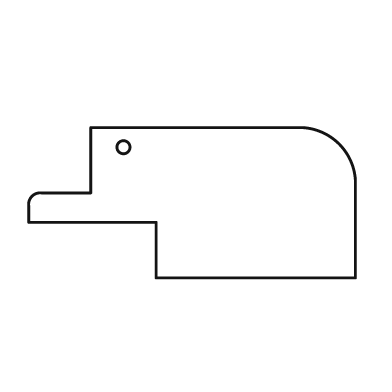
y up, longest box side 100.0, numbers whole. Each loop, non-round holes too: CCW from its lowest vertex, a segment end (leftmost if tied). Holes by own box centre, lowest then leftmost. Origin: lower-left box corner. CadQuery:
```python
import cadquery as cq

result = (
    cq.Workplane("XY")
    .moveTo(39.0, 0.0)
    .lineTo(100.0, 0.0)
    .lineTo(100.0, 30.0)
    .threePointArc((95.0, 41.0), (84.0, 46.0))
    .lineTo(19.0, 46.0)
    .lineTo(19.0, 26.0)
    .lineTo(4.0, 26.0)
    .threePointArc((1.0, 25.0), (0.0, 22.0))
    .lineTo(0.0, 17.0)
    .lineTo(39.0, 17.0)
    .close()
    .moveTo(29.0, 40.0)
    .circle(2.0)
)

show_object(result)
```